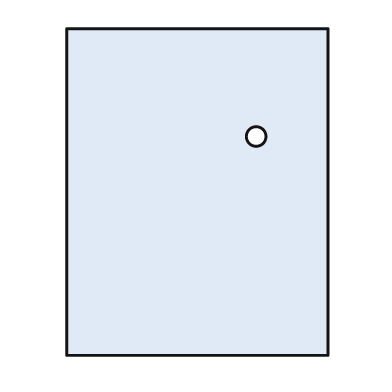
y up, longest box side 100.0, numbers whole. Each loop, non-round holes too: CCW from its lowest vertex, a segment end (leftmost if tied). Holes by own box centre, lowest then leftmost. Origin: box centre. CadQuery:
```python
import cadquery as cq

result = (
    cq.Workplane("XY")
    .moveTo(-40.0, -50.0)
    .lineTo(40.0, -50.0)
    .lineTo(40.0, 50.0)
    .lineTo(-40.0, 50.0)
    .close()
    .moveTo(18.0, 17.0)
    .circle(3.0)
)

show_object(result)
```